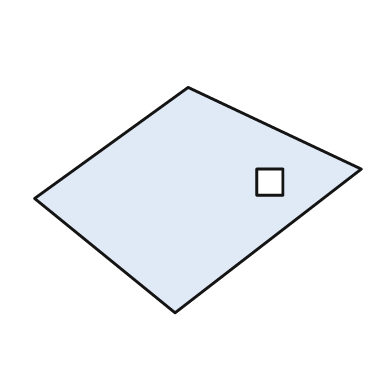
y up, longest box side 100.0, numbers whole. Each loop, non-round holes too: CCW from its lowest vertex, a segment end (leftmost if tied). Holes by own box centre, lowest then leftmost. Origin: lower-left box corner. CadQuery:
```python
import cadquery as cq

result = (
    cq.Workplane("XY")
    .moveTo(43.0, 0.0)
    .lineTo(100.0, 44.0)
    .lineTo(47.0, 69.0)
    .lineTo(0.0, 35.0)
    .close()
    .moveTo(68.0, 36.0)
    .lineTo(76.0, 36.0)
    .lineTo(76.0, 44.0)
    .lineTo(68.0, 44.0)
    .close()
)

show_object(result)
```